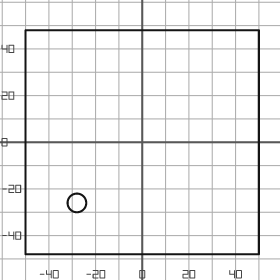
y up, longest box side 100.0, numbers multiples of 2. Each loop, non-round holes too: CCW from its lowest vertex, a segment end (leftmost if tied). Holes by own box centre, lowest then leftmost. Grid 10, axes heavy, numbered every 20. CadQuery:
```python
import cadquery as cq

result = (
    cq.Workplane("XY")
    .moveTo(-50.0, -48.0)
    .lineTo(50.0, -48.0)
    .lineTo(50.0, 48.0)
    .lineTo(-50.0, 48.0)
    .close()
    .moveTo(-28.0, -26.0)
    .circle(4.0)
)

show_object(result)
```